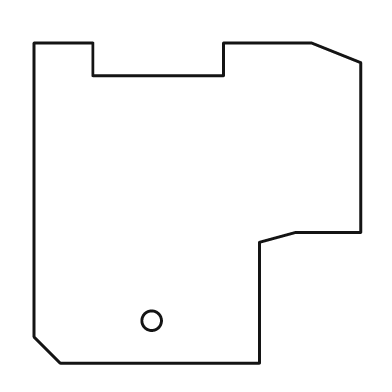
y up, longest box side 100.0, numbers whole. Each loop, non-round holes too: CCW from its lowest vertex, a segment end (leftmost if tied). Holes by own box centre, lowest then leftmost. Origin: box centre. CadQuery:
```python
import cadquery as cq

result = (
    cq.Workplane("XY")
    .moveTo(-42.0, -49.0)
    .lineTo(19.0, -49.0)
    .lineTo(19.0, -12.0)
    .lineTo(30.0, -9.0)
    .lineTo(50.0, -9.0)
    .lineTo(50.0, 43.0)
    .lineTo(35.0, 49.0)
    .lineTo(8.0, 49.0)
    .lineTo(8.0, 39.0)
    .lineTo(-32.0, 39.0)
    .lineTo(-32.0, 49.0)
    .lineTo(-50.0, 49.0)
    .lineTo(-50.0, -41.0)
    .close()
    .moveTo(-14.0, -36.0)
    .circle(3.0)
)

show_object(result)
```